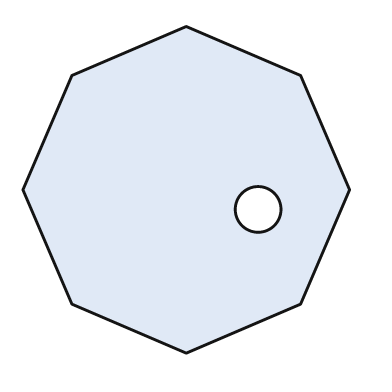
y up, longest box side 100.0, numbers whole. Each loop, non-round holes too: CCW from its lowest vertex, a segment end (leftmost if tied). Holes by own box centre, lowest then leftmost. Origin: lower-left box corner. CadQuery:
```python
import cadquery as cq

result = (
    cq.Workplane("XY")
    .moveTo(50.0, 0.0)
    .lineTo(85.0, 15.0)
    .lineTo(100.0, 50.0)
    .lineTo(85.0, 85.0)
    .lineTo(50.0, 100.0)
    .lineTo(15.0, 85.0)
    .lineTo(0.0, 50.0)
    .lineTo(15.0, 15.0)
    .close()
    .moveTo(72.0, 44.0)
    .circle(7.0)
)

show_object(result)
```